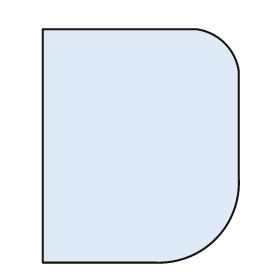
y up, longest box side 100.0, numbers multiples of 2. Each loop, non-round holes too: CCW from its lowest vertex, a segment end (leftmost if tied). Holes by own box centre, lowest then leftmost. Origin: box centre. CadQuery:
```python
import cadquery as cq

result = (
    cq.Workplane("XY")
    .moveTo(-42.0, -50.0)
    .lineTo(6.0, -50.0)
    .threePointArc((32.0, -40.0), (42.0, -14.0))
    .lineTo(42.0, 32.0)
    .threePointArc((36.0, 44.0), (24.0, 50.0))
    .lineTo(-42.0, 50.0)
    .close()
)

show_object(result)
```